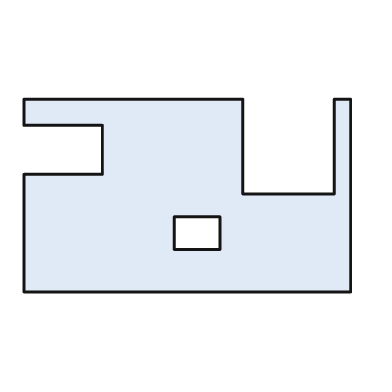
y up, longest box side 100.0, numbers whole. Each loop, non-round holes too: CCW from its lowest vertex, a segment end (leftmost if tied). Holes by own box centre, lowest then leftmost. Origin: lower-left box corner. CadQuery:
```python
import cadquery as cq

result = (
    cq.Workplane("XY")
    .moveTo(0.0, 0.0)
    .lineTo(100.0, 0.0)
    .lineTo(100.0, 59.0)
    .lineTo(95.0, 59.0)
    .lineTo(95.0, 30.0)
    .lineTo(67.0, 30.0)
    .lineTo(67.0, 59.0)
    .lineTo(0.0, 59.0)
    .lineTo(0.0, 51.0)
    .lineTo(24.0, 51.0)
    .lineTo(24.0, 36.0)
    .lineTo(0.0, 36.0)
    .close()
    .moveTo(46.0, 13.0)
    .lineTo(60.0, 13.0)
    .lineTo(60.0, 23.0)
    .lineTo(46.0, 23.0)
    .close()
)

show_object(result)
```